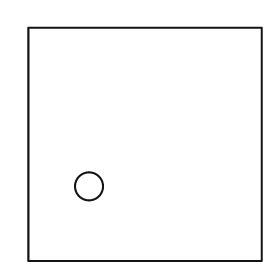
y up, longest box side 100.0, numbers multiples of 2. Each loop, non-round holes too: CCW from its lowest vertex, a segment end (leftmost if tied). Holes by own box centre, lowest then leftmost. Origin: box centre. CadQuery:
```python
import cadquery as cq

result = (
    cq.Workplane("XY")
    .moveTo(-50.0, -50.0)
    .lineTo(50.0, -50.0)
    .lineTo(50.0, 50.0)
    .lineTo(-50.0, 50.0)
    .close()
    .moveTo(-24.0, -18.0)
    .circle(6.0)
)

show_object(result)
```